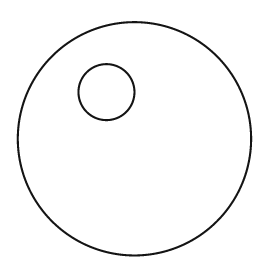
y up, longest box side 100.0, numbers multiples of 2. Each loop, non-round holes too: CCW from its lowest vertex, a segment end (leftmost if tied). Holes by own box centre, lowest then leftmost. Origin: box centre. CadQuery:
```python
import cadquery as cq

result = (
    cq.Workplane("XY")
    .moveTo(0.0, 0.0)
    .circle(50.0)
    .moveTo(-12.0, 20.0)
    .circle(12.0)
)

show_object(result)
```